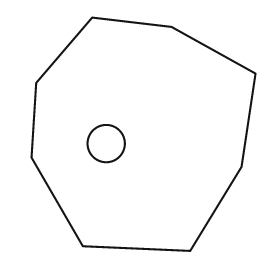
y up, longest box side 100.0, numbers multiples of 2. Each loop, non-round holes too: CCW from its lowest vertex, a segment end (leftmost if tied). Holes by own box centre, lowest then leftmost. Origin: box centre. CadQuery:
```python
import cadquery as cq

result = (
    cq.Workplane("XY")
    .moveTo(20.0, -50.0)
    .lineTo(42.0, -14.0)
    .lineTo(48.0, 26.0)
    .lineTo(12.0, 46.0)
    .lineTo(-22.0, 50.0)
    .lineTo(-46.0, 22.0)
    .lineTo(-48.0, -10.0)
    .lineTo(-26.0, -48.0)
    .close()
    .moveTo(-16.0, -4.0)
    .circle(8.0)
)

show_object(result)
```